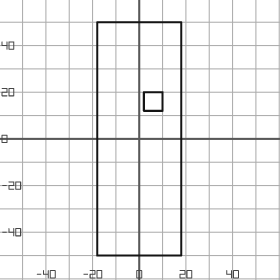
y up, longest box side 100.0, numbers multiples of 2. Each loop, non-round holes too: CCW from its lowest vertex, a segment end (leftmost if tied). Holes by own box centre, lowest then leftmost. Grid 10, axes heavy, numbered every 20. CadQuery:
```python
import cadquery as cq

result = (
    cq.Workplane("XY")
    .moveTo(-18.0, -50.0)
    .lineTo(18.0, -50.0)
    .lineTo(18.0, 50.0)
    .lineTo(-18.0, 50.0)
    .close()
    .moveTo(2.0, 12.0)
    .lineTo(10.0, 12.0)
    .lineTo(10.0, 20.0)
    .lineTo(2.0, 20.0)
    .close()
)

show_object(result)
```